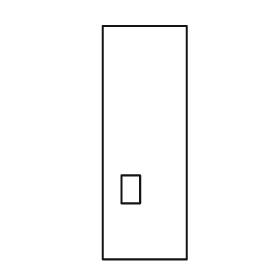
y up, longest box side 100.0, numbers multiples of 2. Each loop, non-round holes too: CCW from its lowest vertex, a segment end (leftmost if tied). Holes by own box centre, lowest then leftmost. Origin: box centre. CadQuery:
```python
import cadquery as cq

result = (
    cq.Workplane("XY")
    .moveTo(-18.0, -50.0)
    .lineTo(18.0, -50.0)
    .lineTo(18.0, 50.0)
    .lineTo(-18.0, 50.0)
    .close()
    .moveTo(-10.0, -26.0)
    .lineTo(-2.0, -26.0)
    .lineTo(-2.0, -14.0)
    .lineTo(-10.0, -14.0)
    .close()
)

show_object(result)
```